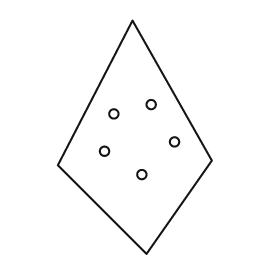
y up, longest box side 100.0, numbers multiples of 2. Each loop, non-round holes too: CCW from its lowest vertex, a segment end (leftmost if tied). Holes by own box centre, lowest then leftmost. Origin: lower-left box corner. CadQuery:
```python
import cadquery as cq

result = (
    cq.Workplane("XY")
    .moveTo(38.0, 0.0)
    .lineTo(66.0, 40.0)
    .lineTo(32.0, 100.0)
    .lineTo(0.0, 38.0)
    .close()
    .moveTo(36.0, 34.0)
    .circle(2.0)
    .moveTo(20.0, 44.0)
    .circle(2.0)
    .moveTo(50.0, 48.0)
    .circle(2.0)
    .moveTo(24.0, 60.0)
    .circle(2.0)
    .moveTo(40.0, 64.0)
    .circle(2.0)
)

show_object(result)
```